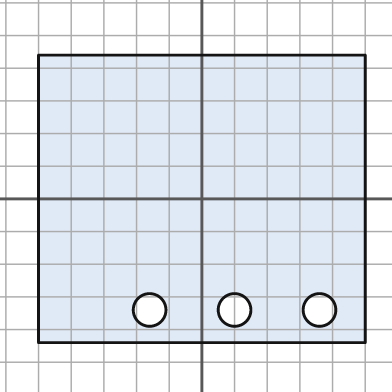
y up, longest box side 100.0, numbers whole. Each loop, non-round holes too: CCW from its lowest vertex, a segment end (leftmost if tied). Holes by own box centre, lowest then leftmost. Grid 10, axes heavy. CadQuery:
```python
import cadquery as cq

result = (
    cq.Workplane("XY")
    .moveTo(-50.0, -44.0)
    .lineTo(50.0, -44.0)
    .lineTo(50.0, 44.0)
    .lineTo(-50.0, 44.0)
    .close()
    .moveTo(-16.0, -34.0)
    .circle(5.0)
    .moveTo(10.0, -34.0)
    .circle(5.0)
    .moveTo(36.0, -34.0)
    .circle(5.0)
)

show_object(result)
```